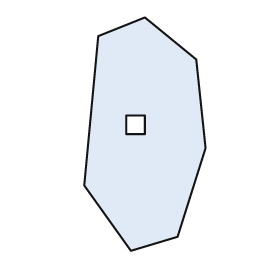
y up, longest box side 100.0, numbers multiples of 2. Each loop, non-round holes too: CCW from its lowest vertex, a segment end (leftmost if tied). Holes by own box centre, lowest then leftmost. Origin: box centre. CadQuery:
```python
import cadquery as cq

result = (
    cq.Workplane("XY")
    .moveTo(-6.0, -50.0)
    .lineTo(14.0, -44.0)
    .lineTo(26.0, -6.0)
    .lineTo(22.0, 32.0)
    .lineTo(0.0, 50.0)
    .lineTo(-20.0, 42.0)
    .lineTo(-26.0, -22.0)
    .close()
    .moveTo(-8.0, 0.0)
    .lineTo(0.0, 0.0)
    .lineTo(0.0, 8.0)
    .lineTo(-8.0, 8.0)
    .close()
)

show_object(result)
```